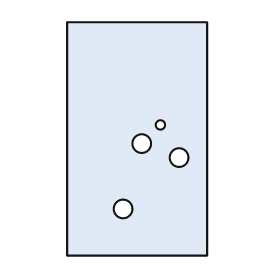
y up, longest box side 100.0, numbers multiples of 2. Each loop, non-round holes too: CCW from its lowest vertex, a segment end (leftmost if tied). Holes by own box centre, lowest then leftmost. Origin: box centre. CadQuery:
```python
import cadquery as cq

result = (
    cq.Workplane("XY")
    .moveTo(-30.0, -50.0)
    .lineTo(30.0, -50.0)
    .lineTo(30.0, 50.0)
    .lineTo(-30.0, 50.0)
    .close()
    .moveTo(-6.0, -30.0)
    .circle(4.0)
    .moveTo(18.0, -8.0)
    .circle(4.0)
    .moveTo(2.0, -2.0)
    .circle(4.0)
    .moveTo(10.0, 6.0)
    .circle(2.0)
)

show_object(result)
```